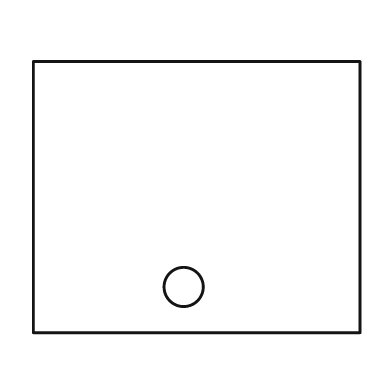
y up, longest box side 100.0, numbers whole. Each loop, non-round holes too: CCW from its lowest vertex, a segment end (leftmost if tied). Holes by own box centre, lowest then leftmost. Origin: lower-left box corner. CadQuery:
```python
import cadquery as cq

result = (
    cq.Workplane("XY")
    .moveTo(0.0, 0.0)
    .lineTo(100.0, 0.0)
    .lineTo(100.0, 83.0)
    .lineTo(0.0, 83.0)
    .close()
    .moveTo(46.0, 14.0)
    .circle(6.0)
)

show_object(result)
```